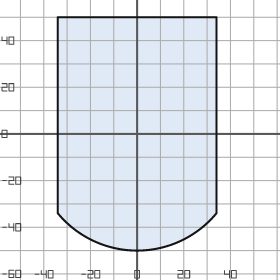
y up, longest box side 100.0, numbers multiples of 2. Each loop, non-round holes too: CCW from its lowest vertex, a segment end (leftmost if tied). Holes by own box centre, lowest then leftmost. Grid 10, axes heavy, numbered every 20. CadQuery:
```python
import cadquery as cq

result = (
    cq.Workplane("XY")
    .moveTo(-34.0, -34.0)
    .threePointArc((0.0, -50.0), (34.0, -34.0))
    .lineTo(34.0, 50.0)
    .lineTo(-34.0, 50.0)
    .close()
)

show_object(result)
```